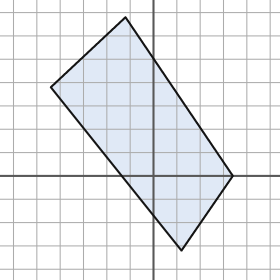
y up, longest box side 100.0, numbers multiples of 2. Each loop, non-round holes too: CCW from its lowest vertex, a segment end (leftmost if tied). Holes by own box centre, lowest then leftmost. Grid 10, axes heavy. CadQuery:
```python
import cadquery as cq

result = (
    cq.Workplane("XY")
    .moveTo(12.0, -32.0)
    .lineTo(34.0, 0.0)
    .lineTo(-12.0, 68.0)
    .lineTo(-44.0, 38.0)
    .close()
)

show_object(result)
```